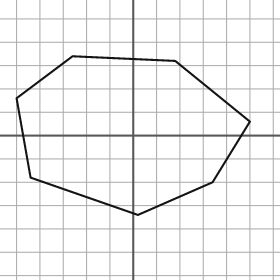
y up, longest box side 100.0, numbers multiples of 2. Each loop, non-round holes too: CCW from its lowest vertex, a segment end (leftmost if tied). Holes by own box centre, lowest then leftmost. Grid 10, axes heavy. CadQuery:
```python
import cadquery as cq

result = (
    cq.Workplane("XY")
    .moveTo(2.0, -34.0)
    .lineTo(34.0, -20.0)
    .lineTo(50.0, 6.0)
    .lineTo(18.0, 32.0)
    .lineTo(-26.0, 34.0)
    .lineTo(-50.0, 16.0)
    .lineTo(-44.0, -18.0)
    .close()
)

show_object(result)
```